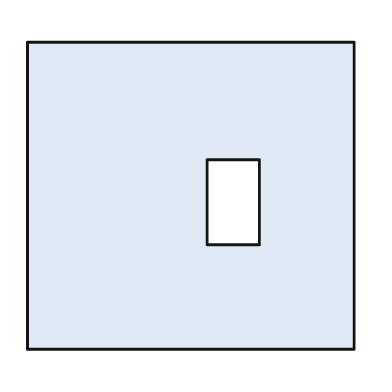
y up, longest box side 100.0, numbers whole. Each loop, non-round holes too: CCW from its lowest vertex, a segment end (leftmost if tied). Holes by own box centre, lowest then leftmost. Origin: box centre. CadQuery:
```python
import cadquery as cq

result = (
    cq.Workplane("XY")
    .moveTo(-50.0, -47.0)
    .lineTo(50.0, -47.0)
    .lineTo(50.0, 47.0)
    .lineTo(-50.0, 47.0)
    .close()
    .moveTo(5.0, -15.0)
    .lineTo(21.0, -15.0)
    .lineTo(21.0, 11.0)
    .lineTo(5.0, 11.0)
    .close()
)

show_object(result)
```